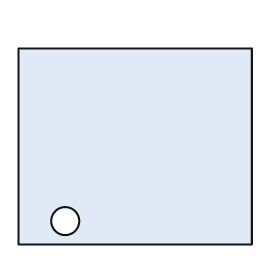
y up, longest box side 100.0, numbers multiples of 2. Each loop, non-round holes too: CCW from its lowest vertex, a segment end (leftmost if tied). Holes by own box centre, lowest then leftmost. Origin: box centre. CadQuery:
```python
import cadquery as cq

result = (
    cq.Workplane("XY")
    .moveTo(-50.0, -42.0)
    .lineTo(50.0, -42.0)
    .lineTo(50.0, 42.0)
    .lineTo(-50.0, 42.0)
    .close()
    .moveTo(-30.0, -32.0)
    .circle(6.0)
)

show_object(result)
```